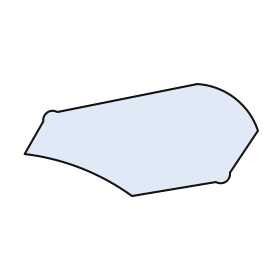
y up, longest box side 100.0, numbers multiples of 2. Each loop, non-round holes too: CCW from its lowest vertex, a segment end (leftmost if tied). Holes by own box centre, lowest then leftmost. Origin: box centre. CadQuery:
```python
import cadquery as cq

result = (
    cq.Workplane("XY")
    .moveTo(-4.0, -24.0)
    .lineTo(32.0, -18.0)
    .threePointArc((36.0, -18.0), (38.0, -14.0))
    .lineTo(50.0, 4.0)
    .threePointArc((40.0, 18.0), (24.0, 24.0))
    .lineTo(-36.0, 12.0)
    .threePointArc((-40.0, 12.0), (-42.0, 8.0))
    .lineTo(-50.0, -6.0)
    .threePointArc((-26.0, -12.0), (-4.0, -24.0))
    .close()
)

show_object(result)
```